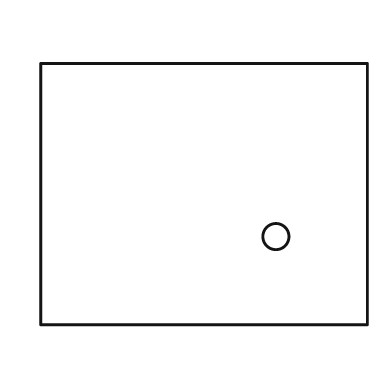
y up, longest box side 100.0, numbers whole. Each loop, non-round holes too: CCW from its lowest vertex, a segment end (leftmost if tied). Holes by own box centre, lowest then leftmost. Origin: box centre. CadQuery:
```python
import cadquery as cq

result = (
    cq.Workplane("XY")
    .moveTo(-50.0, -40.0)
    .lineTo(50.0, -40.0)
    .lineTo(50.0, 40.0)
    .lineTo(-50.0, 40.0)
    .close()
    .moveTo(22.0, -13.0)
    .circle(4.0)
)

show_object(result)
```